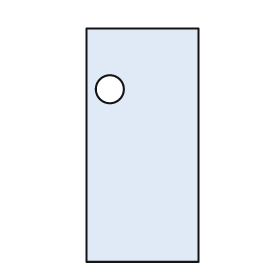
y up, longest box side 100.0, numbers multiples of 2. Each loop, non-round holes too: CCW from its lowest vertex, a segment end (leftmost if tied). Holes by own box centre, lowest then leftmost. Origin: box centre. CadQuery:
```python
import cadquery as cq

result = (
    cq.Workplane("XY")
    .moveTo(-24.0, -50.0)
    .lineTo(24.0, -50.0)
    .lineTo(24.0, 50.0)
    .lineTo(-24.0, 50.0)
    .close()
    .moveTo(-14.0, 24.0)
    .circle(6.0)
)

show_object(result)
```